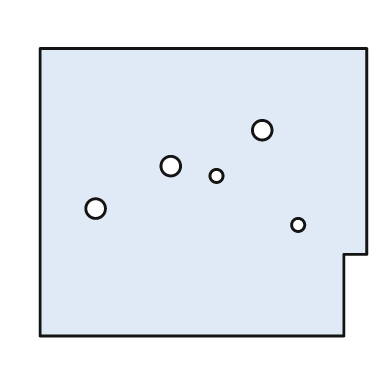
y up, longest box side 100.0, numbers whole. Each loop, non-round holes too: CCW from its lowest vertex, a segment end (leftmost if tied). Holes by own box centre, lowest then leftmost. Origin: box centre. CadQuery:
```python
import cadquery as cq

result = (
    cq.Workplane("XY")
    .moveTo(-50.0, -44.0)
    .lineTo(43.0, -44.0)
    .lineTo(43.0, -19.0)
    .lineTo(50.0, -19.0)
    .lineTo(50.0, 44.0)
    .lineTo(-50.0, 44.0)
    .close()
    .moveTo(29.0, -10.0)
    .circle(2.0)
    .moveTo(-33.0, -5.0)
    .circle(3.0)
    .moveTo(4.0, 5.0)
    .circle(2.0)
    .moveTo(-10.0, 8.0)
    .circle(3.0)
    .moveTo(18.0, 19.0)
    .circle(3.0)
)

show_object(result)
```